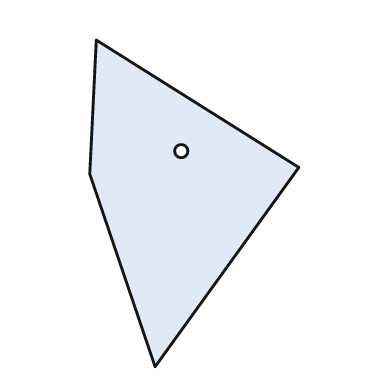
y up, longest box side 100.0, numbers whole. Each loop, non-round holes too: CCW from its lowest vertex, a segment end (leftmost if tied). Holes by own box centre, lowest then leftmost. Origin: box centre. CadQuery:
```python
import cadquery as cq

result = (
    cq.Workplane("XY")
    .moveTo(-12.0, -50.0)
    .lineTo(32.0, 11.0)
    .lineTo(-30.0, 50.0)
    .lineTo(-32.0, 9.0)
    .close()
    .moveTo(-4.0, 16.0)
    .circle(2.0)
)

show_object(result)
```